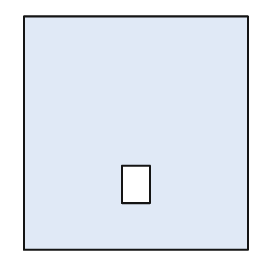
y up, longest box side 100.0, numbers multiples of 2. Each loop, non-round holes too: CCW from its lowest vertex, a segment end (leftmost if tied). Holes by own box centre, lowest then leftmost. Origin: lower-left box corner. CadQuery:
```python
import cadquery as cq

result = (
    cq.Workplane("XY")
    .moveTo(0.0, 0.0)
    .lineTo(96.0, 0.0)
    .lineTo(96.0, 100.0)
    .lineTo(0.0, 100.0)
    .close()
    .moveTo(42.0, 20.0)
    .lineTo(54.0, 20.0)
    .lineTo(54.0, 36.0)
    .lineTo(42.0, 36.0)
    .close()
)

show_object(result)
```